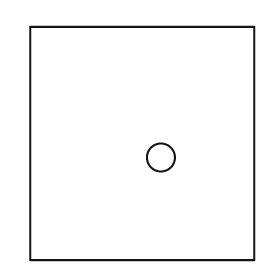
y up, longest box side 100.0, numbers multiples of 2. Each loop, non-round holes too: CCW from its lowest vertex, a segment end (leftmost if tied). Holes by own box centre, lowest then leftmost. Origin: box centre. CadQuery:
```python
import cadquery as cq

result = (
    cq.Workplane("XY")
    .moveTo(-48.0, -50.0)
    .lineTo(48.0, -50.0)
    .lineTo(48.0, 50.0)
    .lineTo(-48.0, 50.0)
    .close()
    .moveTo(8.0, -6.0)
    .circle(6.0)
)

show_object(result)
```